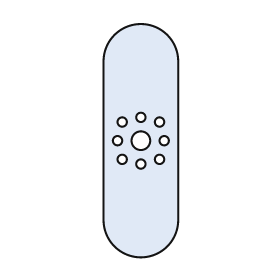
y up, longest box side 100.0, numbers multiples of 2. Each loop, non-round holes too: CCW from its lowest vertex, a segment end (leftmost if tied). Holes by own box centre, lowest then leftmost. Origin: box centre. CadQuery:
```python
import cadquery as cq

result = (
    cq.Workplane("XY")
    .moveTo(-16.0, -34.0)
    .threePointArc((0.0, -50.0), (16.0, -34.0))
    .lineTo(16.0, 34.0)
    .threePointArc((0.0, 50.0), (-16.0, 34.0))
    .close()
    .moveTo(0.0, -10.0)
    .circle(2.0)
    .moveTo(-8.0, -8.0)
    .circle(2.0)
    .moveTo(8.0, -8.0)
    .circle(2.0)
    .moveTo(-10.0, 0.0)
    .circle(2.0)
    .moveTo(0.0, 0.0)
    .circle(4.0)
    .moveTo(10.0, 0.0)
    .circle(2.0)
    .moveTo(-8.0, 8.0)
    .circle(2.0)
    .moveTo(8.0, 8.0)
    .circle(2.0)
    .moveTo(0.0, 10.0)
    .circle(2.0)
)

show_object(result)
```